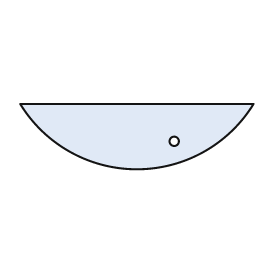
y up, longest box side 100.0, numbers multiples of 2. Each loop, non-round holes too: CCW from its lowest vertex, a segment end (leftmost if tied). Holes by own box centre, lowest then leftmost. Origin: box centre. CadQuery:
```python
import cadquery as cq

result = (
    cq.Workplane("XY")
    .moveTo(-50.0, 14.0)
    .threePointArc((0.0, -14.0), (50.0, 14.0))
    .close()
    .moveTo(16.0, -2.0)
    .circle(2.0)
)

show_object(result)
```